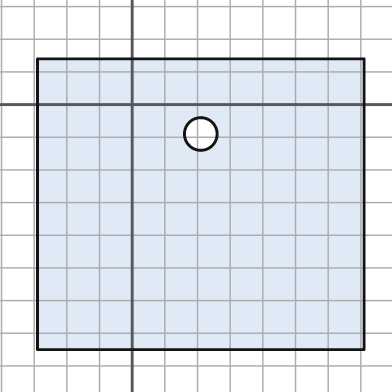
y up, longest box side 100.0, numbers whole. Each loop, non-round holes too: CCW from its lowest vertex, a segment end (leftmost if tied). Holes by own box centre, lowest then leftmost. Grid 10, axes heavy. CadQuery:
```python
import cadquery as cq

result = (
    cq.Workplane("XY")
    .moveTo(-29.0, -75.0)
    .lineTo(71.0, -75.0)
    .lineTo(71.0, 14.0)
    .lineTo(-29.0, 14.0)
    .close()
    .moveTo(21.0, -9.0)
    .circle(5.0)
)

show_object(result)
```